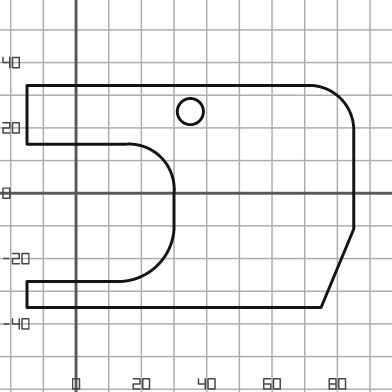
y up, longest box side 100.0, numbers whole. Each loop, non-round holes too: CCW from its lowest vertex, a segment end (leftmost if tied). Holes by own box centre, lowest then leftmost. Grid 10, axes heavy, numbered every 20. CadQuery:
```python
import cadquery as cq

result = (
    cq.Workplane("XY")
    .moveTo(-15.0, -35.0)
    .lineTo(75.0, -35.0)
    .lineTo(85.0, -11.0)
    .lineTo(85.0, 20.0)
    .threePointArc((81.0, 29.0), (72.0, 33.0))
    .lineTo(-15.0, 33.0)
    .lineTo(-15.0, 15.0)
    .lineTo(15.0, 15.0)
    .threePointArc((26.0, 11.0), (30.0, 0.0))
    .lineTo(30.0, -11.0)
    .threePointArc((25.0, -22.0), (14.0, -27.0))
    .lineTo(-15.0, -27.0)
    .close()
    .moveTo(35.0, 25.0)
    .circle(4.0)
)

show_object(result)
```